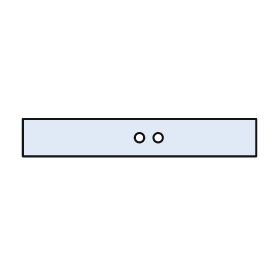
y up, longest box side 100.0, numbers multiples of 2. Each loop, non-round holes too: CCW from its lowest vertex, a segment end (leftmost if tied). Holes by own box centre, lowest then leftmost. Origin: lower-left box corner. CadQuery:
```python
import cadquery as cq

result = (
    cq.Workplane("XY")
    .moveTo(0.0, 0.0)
    .lineTo(100.0, 0.0)
    .lineTo(100.0, 16.0)
    .lineTo(0.0, 16.0)
    .close()
    .moveTo(50.0, 8.0)
    .circle(2.0)
    .moveTo(58.0, 8.0)
    .circle(2.0)
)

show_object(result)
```